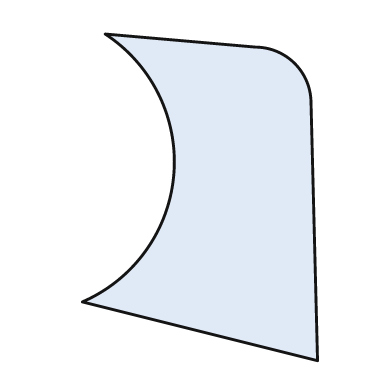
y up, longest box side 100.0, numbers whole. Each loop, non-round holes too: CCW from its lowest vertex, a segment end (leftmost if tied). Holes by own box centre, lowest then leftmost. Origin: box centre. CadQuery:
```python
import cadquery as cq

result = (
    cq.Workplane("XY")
    .moveTo(36.0, -50.0)
    .lineTo(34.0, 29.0)
    .threePointArc((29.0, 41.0), (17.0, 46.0))
    .lineTo(-29.0, 50.0)
    .threePointArc((-8.0, 7.0), (-36.0, -32.0))
    .close()
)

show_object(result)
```